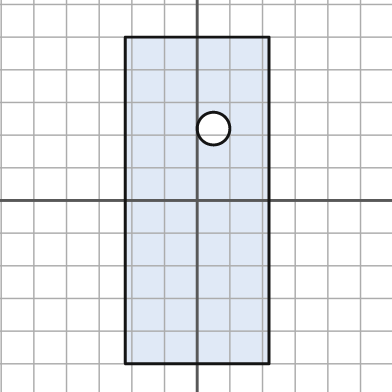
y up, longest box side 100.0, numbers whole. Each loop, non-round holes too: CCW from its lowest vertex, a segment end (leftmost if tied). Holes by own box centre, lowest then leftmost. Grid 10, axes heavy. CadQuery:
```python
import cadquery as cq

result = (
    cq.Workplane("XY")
    .moveTo(-22.0, -50.0)
    .lineTo(22.0, -50.0)
    .lineTo(22.0, 50.0)
    .lineTo(-22.0, 50.0)
    .close()
    .moveTo(5.0, 22.0)
    .circle(5.0)
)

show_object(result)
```